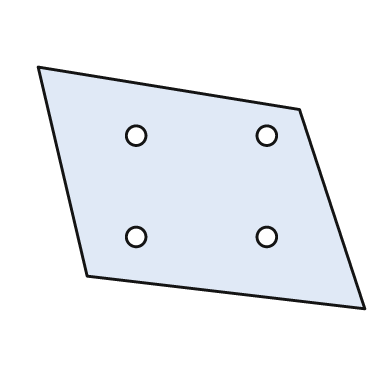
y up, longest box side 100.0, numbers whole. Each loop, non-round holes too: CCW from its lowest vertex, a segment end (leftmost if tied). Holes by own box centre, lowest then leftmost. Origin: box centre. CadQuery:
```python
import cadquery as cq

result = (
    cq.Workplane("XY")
    .moveTo(50.0, -37.0)
    .lineTo(30.0, 24.0)
    .lineTo(-50.0, 37.0)
    .lineTo(-35.0, -27.0)
    .close()
    .moveTo(-20.0, -15.0)
    .circle(3.0)
    .moveTo(20.0, -15.0)
    .circle(3.0)
    .moveTo(-20.0, 16.0)
    .circle(3.0)
    .moveTo(20.0, 16.0)
    .circle(3.0)
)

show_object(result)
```